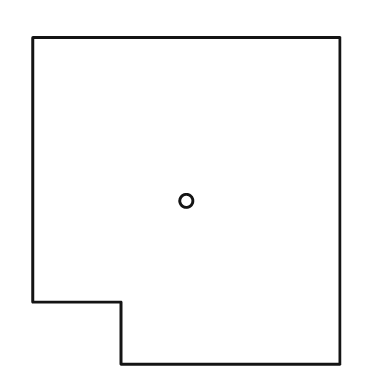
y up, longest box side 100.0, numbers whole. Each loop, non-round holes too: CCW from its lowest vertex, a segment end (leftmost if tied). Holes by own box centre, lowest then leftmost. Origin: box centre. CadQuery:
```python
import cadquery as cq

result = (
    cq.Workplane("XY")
    .moveTo(-20.0, -50.0)
    .lineTo(47.0, -50.0)
    .lineTo(47.0, 50.0)
    .lineTo(-47.0, 50.0)
    .lineTo(-47.0, -31.0)
    .lineTo(-20.0, -31.0)
    .close()
    .moveTo(0.0, 0.0)
    .circle(2.0)
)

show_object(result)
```